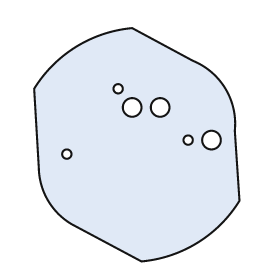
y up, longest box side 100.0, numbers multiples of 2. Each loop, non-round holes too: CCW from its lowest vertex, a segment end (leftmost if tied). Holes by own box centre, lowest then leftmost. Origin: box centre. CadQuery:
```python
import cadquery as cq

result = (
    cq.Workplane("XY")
    .moveTo(2.0, -50.0)
    .threePointArc((26.0, -42.0), (44.0, -24.0))
    .lineTo(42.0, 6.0)
    .threePointArc((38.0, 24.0), (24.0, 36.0))
    .lineTo(-2.0, 50.0)
    .threePointArc((-26.0, 42.0), (-44.0, 24.0))
    .lineTo(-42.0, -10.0)
    .threePointArc((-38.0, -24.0), (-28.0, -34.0))
    .close()
    .moveTo(-30.0, -4.0)
    .circle(2.0)
    .moveTo(22.0, 2.0)
    .circle(2.0)
    .moveTo(32.0, 2.0)
    .circle(4.0)
    .moveTo(-2.0, 16.0)
    .circle(4.0)
    .moveTo(10.0, 16.0)
    .circle(4.0)
    .moveTo(-8.0, 24.0)
    .circle(2.0)
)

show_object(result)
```